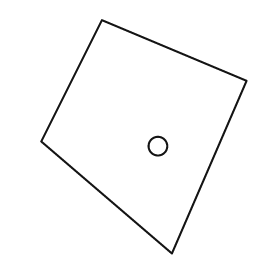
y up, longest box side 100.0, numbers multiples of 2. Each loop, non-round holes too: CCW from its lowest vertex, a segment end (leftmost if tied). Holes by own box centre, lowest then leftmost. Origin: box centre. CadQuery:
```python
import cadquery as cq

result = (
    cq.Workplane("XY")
    .moveTo(12.0, -50.0)
    .lineTo(44.0, 24.0)
    .lineTo(-18.0, 50.0)
    .lineTo(-44.0, -2.0)
    .close()
    .moveTo(6.0, -4.0)
    .circle(4.0)
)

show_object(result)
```